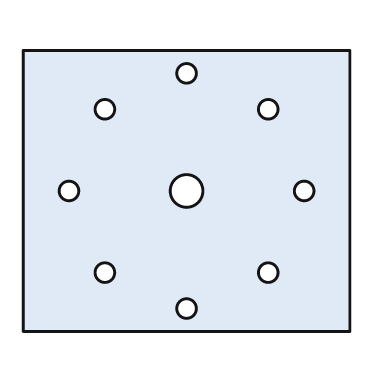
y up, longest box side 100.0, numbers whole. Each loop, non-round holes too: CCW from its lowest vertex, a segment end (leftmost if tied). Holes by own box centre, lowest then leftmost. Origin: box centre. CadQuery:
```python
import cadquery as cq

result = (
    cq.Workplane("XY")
    .moveTo(-50.0, -43.0)
    .lineTo(50.0, -43.0)
    .lineTo(50.0, 43.0)
    .lineTo(-50.0, 43.0)
    .close()
    .moveTo(0.0, -36.0)
    .circle(3.0)
    .moveTo(-25.0, -25.0)
    .circle(3.0)
    .moveTo(25.0, -25.0)
    .circle(3.0)
    .moveTo(-36.0, 0.0)
    .circle(3.0)
    .moveTo(0.0, 0.0)
    .circle(5.0)
    .moveTo(36.0, 0.0)
    .circle(3.0)
    .moveTo(-25.0, 25.0)
    .circle(3.0)
    .moveTo(25.0, 25.0)
    .circle(3.0)
    .moveTo(0.0, 36.0)
    .circle(3.0)
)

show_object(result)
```